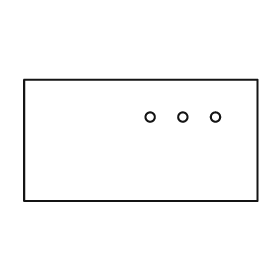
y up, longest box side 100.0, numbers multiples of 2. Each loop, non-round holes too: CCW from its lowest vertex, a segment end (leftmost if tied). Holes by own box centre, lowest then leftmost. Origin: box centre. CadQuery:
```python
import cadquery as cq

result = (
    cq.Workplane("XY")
    .moveTo(-50.0, -26.0)
    .lineTo(50.0, -26.0)
    .lineTo(50.0, 26.0)
    .lineTo(-50.0, 26.0)
    .close()
    .moveTo(4.0, 10.0)
    .circle(2.0)
    .moveTo(18.0, 10.0)
    .circle(2.0)
    .moveTo(32.0, 10.0)
    .circle(2.0)
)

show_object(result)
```